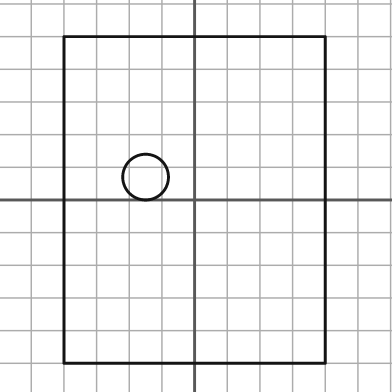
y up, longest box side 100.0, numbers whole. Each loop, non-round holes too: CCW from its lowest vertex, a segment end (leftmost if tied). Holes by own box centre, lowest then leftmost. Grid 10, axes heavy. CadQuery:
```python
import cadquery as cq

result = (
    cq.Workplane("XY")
    .moveTo(-40.0, -50.0)
    .lineTo(40.0, -50.0)
    .lineTo(40.0, 50.0)
    .lineTo(-40.0, 50.0)
    .close()
    .moveTo(-15.0, 7.0)
    .circle(7.0)
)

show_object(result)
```